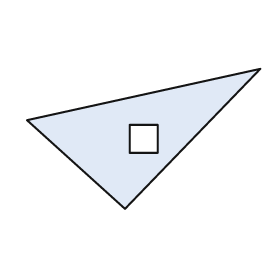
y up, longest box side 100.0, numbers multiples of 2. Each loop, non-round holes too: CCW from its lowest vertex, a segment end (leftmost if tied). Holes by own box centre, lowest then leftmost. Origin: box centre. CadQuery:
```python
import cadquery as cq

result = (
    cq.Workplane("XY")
    .moveTo(-8.0, -30.0)
    .lineTo(50.0, 30.0)
    .lineTo(-50.0, 8.0)
    .close()
    .moveTo(-6.0, -6.0)
    .lineTo(6.0, -6.0)
    .lineTo(6.0, 6.0)
    .lineTo(-6.0, 6.0)
    .close()
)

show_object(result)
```